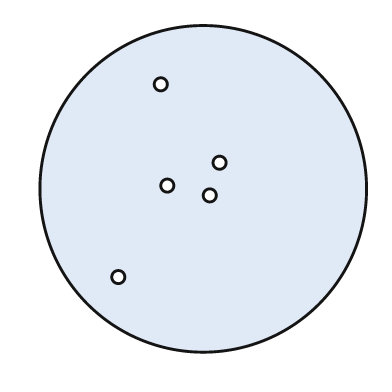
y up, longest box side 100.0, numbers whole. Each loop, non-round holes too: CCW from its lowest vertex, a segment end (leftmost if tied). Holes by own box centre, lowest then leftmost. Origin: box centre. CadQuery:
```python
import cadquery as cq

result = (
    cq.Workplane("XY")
    .moveTo(0.0, 0.0)
    .circle(50.0)
    .moveTo(-26.0, -27.0)
    .circle(2.0)
    .moveTo(2.0, -2.0)
    .circle(2.0)
    .moveTo(-11.0, 1.0)
    .circle(2.0)
    .moveTo(5.0, 8.0)
    .circle(2.0)
    .moveTo(-13.0, 32.0)
    .circle(2.0)
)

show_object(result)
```